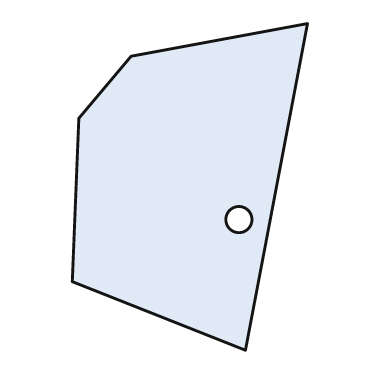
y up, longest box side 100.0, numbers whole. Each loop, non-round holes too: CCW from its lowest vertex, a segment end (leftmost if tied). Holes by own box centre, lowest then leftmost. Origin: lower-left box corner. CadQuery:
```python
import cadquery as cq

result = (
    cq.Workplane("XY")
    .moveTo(53.0, 0.0)
    .lineTo(72.0, 100.0)
    .lineTo(18.0, 90.0)
    .lineTo(2.0, 71.0)
    .lineTo(0.0, 21.0)
    .close()
    .moveTo(51.0, 40.0)
    .circle(4.0)
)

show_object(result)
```